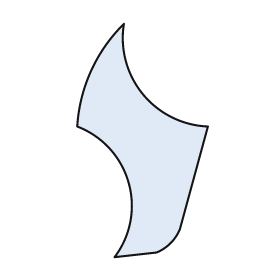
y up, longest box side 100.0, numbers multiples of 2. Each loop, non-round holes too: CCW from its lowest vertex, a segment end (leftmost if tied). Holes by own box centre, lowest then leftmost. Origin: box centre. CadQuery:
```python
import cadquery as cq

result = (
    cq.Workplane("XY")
    .moveTo(-12.0, -50.0)
    .lineTo(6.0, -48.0)
    .threePointArc((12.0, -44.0), (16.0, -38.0))
    .lineTo(28.0, 6.0)
    .threePointArc((0.0, 20.0), (-8.0, 50.0))
    .threePointArc((-22.0, 30.0), (-28.0, 6.0))
    .threePointArc((-6.0, -18.0), (-12.0, -50.0))
    .close()
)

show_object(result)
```